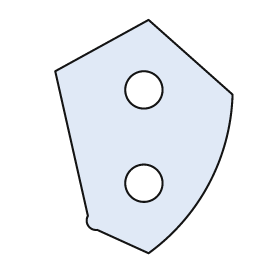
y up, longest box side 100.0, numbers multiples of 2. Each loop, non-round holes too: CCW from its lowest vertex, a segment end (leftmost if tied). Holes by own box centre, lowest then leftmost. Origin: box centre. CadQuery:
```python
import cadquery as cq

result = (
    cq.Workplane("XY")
    .moveTo(2.0, -50.0)
    .threePointArc((28.0, -20.0), (38.0, 18.0))
    .lineTo(2.0, 50.0)
    .lineTo(-38.0, 28.0)
    .lineTo(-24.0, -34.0)
    .threePointArc((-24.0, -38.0), (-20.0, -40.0))
    .close()
    .moveTo(0.0, -20.0)
    .circle(8.0)
    .moveTo(0.0, 20.0)
    .circle(8.0)
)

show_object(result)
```